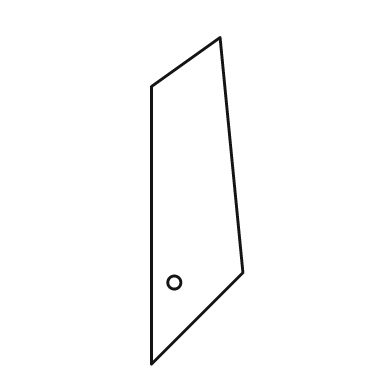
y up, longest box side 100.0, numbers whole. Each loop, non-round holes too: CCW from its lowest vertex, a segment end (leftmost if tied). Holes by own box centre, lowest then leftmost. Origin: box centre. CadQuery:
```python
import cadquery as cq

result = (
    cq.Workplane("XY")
    .moveTo(-14.0, -50.0)
    .lineTo(14.0, -22.0)
    .lineTo(7.0, 50.0)
    .lineTo(-14.0, 35.0)
    .close()
    .moveTo(-7.0, -25.0)
    .circle(2.0)
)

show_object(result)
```